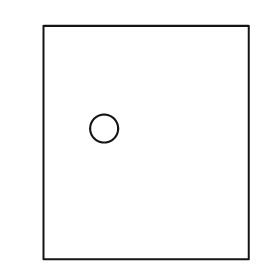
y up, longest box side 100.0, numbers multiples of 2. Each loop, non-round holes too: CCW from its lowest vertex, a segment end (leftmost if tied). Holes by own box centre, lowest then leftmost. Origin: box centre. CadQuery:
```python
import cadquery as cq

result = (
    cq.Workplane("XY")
    .moveTo(-44.0, -50.0)
    .lineTo(44.0, -50.0)
    .lineTo(44.0, 50.0)
    .lineTo(-44.0, 50.0)
    .close()
    .moveTo(-18.0, 6.0)
    .circle(6.0)
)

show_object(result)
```